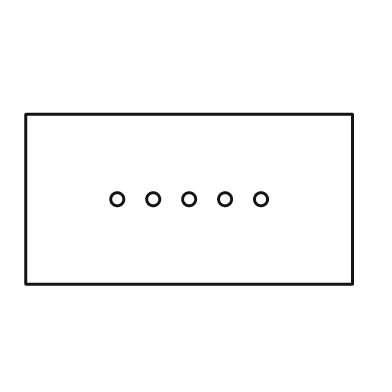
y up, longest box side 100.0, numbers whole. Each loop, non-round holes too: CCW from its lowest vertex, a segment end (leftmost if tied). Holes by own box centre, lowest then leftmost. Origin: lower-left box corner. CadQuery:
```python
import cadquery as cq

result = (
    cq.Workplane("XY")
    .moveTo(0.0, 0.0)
    .lineTo(100.0, 0.0)
    .lineTo(100.0, 52.0)
    .lineTo(0.0, 52.0)
    .close()
    .moveTo(28.0, 26.0)
    .circle(2.0)
    .moveTo(39.0, 26.0)
    .circle(2.0)
    .moveTo(50.0, 26.0)
    .circle(2.0)
    .moveTo(61.0, 26.0)
    .circle(2.0)
    .moveTo(72.0, 26.0)
    .circle(2.0)
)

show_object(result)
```